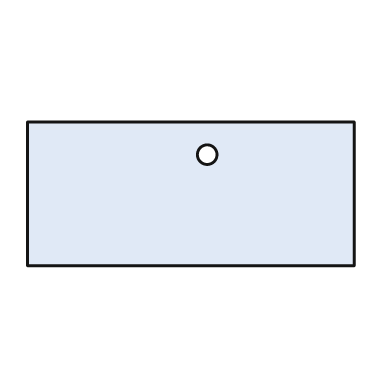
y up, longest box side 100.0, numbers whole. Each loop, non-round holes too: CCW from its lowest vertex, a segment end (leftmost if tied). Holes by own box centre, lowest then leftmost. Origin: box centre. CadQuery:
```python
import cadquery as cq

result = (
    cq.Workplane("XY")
    .moveTo(-50.0, -22.0)
    .lineTo(50.0, -22.0)
    .lineTo(50.0, 22.0)
    .lineTo(-50.0, 22.0)
    .close()
    .moveTo(5.0, 12.0)
    .circle(3.0)
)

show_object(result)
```